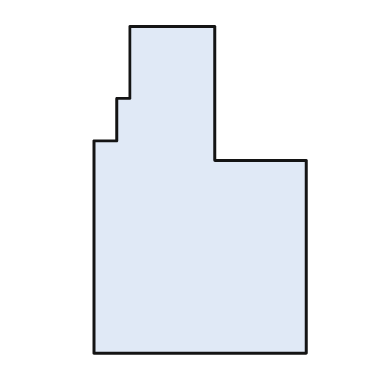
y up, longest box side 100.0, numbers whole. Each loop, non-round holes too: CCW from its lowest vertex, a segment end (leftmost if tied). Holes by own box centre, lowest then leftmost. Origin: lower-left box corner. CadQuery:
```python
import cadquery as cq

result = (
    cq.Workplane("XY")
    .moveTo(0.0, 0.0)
    .lineTo(65.0, 0.0)
    .lineTo(65.0, 59.0)
    .lineTo(37.0, 59.0)
    .lineTo(37.0, 100.0)
    .lineTo(11.0, 100.0)
    .lineTo(11.0, 78.0)
    .lineTo(7.0, 78.0)
    .lineTo(7.0, 65.0)
    .lineTo(0.0, 65.0)
    .close()
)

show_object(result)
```